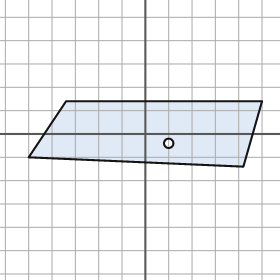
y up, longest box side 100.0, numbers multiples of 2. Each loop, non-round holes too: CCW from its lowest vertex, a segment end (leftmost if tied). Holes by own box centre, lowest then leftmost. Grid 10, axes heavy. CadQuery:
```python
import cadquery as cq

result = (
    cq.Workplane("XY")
    .moveTo(42.0, -14.0)
    .lineTo(50.0, 14.0)
    .lineTo(-34.0, 14.0)
    .lineTo(-50.0, -10.0)
    .close()
    .moveTo(10.0, -4.0)
    .circle(2.0)
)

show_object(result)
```